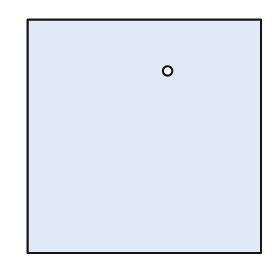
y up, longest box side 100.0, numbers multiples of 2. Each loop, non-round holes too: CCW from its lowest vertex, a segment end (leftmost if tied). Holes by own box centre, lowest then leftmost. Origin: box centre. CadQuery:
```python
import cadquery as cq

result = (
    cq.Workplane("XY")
    .moveTo(-50.0, -50.0)
    .lineTo(50.0, -50.0)
    .lineTo(50.0, 50.0)
    .lineTo(-50.0, 50.0)
    .close()
    .moveTo(10.0, 28.0)
    .circle(2.0)
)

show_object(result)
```